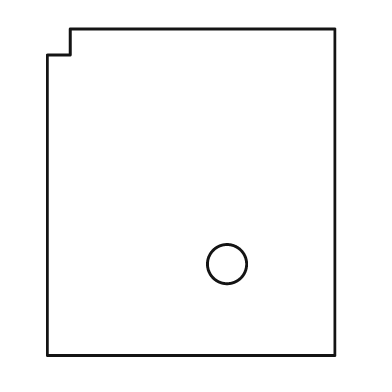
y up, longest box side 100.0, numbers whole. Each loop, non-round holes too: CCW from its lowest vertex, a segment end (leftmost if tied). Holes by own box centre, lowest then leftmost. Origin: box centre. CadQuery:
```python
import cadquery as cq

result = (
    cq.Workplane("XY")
    .moveTo(-44.0, -50.0)
    .lineTo(44.0, -50.0)
    .lineTo(44.0, 50.0)
    .lineTo(-37.0, 50.0)
    .lineTo(-37.0, 42.0)
    .lineTo(-44.0, 42.0)
    .close()
    .moveTo(11.0, -22.0)
    .circle(6.0)
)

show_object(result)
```